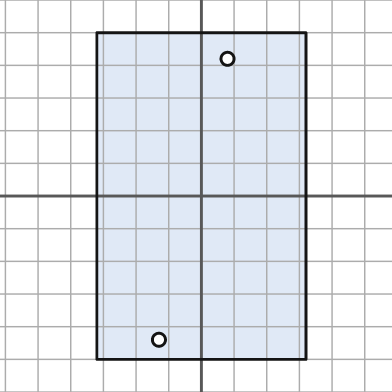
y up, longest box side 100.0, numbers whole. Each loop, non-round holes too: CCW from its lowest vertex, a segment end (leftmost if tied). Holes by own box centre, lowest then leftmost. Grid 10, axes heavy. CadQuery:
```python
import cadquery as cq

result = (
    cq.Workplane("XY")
    .moveTo(-32.0, -50.0)
    .lineTo(32.0, -50.0)
    .lineTo(32.0, 50.0)
    .lineTo(-32.0, 50.0)
    .close()
    .moveTo(-13.0, -44.0)
    .circle(2.0)
    .moveTo(8.0, 42.0)
    .circle(2.0)
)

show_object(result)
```